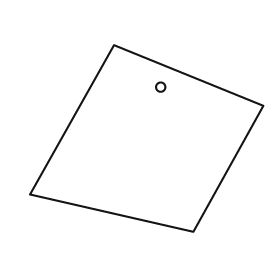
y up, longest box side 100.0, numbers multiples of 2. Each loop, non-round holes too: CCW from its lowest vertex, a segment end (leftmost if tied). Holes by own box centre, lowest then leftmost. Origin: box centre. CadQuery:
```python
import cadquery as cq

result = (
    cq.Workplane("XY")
    .moveTo(20.0, -40.0)
    .lineTo(50.0, 14.0)
    .lineTo(-14.0, 40.0)
    .lineTo(-50.0, -24.0)
    .close()
    .moveTo(6.0, 22.0)
    .circle(2.0)
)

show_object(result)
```